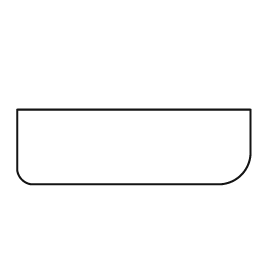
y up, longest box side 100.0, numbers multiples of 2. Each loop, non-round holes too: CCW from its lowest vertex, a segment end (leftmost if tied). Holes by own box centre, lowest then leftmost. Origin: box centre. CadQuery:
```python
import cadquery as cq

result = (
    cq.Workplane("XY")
    .moveTo(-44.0, -16.0)
    .lineTo(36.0, -16.0)
    .threePointArc((46.0, -12.0), (50.0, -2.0))
    .lineTo(50.0, 16.0)
    .lineTo(-50.0, 16.0)
    .lineTo(-50.0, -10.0)
    .threePointArc((-48.0, -14.0), (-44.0, -16.0))
    .close()
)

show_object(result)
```